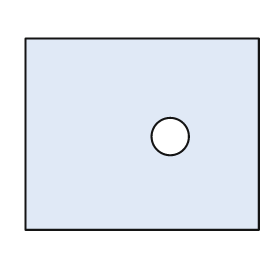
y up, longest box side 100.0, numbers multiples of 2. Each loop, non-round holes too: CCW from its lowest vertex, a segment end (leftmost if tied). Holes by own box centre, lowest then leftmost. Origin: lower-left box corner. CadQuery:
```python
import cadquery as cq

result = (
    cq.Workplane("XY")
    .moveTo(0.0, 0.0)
    .lineTo(100.0, 0.0)
    .lineTo(100.0, 82.0)
    .lineTo(0.0, 82.0)
    .close()
    .moveTo(62.0, 40.0)
    .circle(8.0)
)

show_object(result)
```